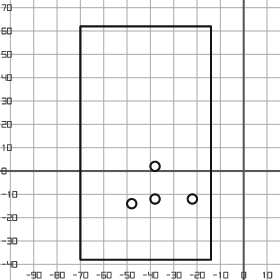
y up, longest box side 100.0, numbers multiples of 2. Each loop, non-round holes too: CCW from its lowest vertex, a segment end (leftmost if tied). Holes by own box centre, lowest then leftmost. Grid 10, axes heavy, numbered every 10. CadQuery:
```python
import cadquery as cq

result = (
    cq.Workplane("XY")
    .moveTo(-70.0, -38.0)
    .lineTo(-14.0, -38.0)
    .lineTo(-14.0, 62.0)
    .lineTo(-70.0, 62.0)
    .close()
    .moveTo(-48.0, -14.0)
    .circle(2.0)
    .moveTo(-38.0, -12.0)
    .circle(2.0)
    .moveTo(-22.0, -12.0)
    .circle(2.0)
    .moveTo(-38.0, 2.0)
    .circle(2.0)
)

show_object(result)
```